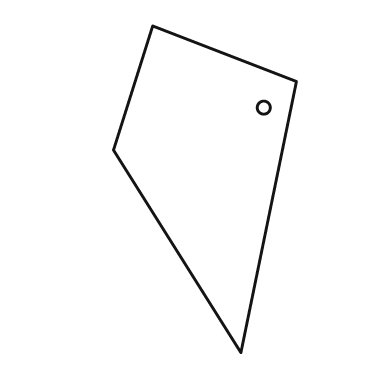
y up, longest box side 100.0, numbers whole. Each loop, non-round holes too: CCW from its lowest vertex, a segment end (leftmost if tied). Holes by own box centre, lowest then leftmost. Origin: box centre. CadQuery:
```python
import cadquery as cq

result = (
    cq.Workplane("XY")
    .moveTo(11.0, -50.0)
    .lineTo(28.0, 33.0)
    .lineTo(-16.0, 50.0)
    .lineTo(-28.0, 12.0)
    .close()
    .moveTo(18.0, 25.0)
    .circle(2.0)
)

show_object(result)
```